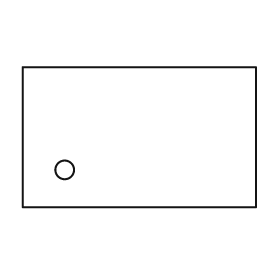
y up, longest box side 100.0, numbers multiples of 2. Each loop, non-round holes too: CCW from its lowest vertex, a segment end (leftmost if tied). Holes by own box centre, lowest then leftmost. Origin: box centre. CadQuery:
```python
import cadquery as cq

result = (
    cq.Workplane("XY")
    .moveTo(-50.0, -30.0)
    .lineTo(50.0, -30.0)
    .lineTo(50.0, 30.0)
    .lineTo(-50.0, 30.0)
    .close()
    .moveTo(-32.0, -14.0)
    .circle(4.0)
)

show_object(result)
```